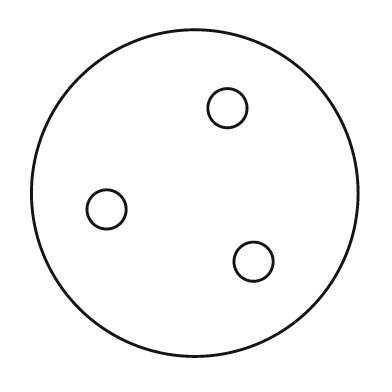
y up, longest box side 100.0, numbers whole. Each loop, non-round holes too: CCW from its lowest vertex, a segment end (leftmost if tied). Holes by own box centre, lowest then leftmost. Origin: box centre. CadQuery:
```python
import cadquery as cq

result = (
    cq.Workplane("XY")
    .moveTo(0.0, 0.0)
    .circle(50.0)
    .moveTo(18.0, -21.0)
    .circle(6.0)
    .moveTo(-27.0, -5.0)
    .circle(6.0)
    .moveTo(10.0, 26.0)
    .circle(6.0)
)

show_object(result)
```